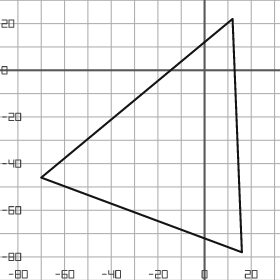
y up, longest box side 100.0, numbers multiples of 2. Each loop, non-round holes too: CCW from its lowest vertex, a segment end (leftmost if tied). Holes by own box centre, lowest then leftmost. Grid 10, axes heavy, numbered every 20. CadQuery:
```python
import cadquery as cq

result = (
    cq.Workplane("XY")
    .moveTo(16.0, -78.0)
    .lineTo(12.0, 22.0)
    .lineTo(-70.0, -46.0)
    .close()
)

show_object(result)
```